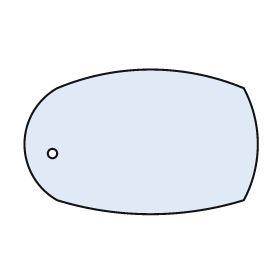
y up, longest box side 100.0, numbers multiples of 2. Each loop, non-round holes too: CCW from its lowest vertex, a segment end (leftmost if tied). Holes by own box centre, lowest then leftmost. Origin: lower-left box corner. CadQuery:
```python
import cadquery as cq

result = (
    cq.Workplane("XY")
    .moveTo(14.0, 6.0)
    .threePointArc((54.0, 0.0), (94.0, 6.0))
    .threePointArc((100.0, 30.0), (94.0, 54.0))
    .threePointArc((54.0, 62.0), (14.0, 54.0))
    .threePointArc((0.0, 30.0), (14.0, 6.0))
    .close()
    .moveTo(12.0, 26.0)
    .circle(2.0)
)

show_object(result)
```